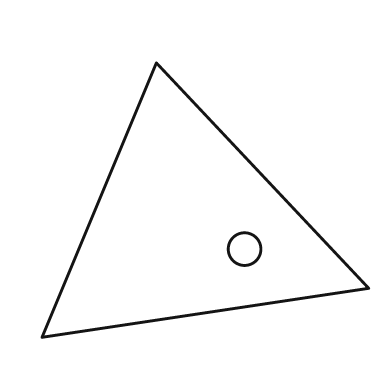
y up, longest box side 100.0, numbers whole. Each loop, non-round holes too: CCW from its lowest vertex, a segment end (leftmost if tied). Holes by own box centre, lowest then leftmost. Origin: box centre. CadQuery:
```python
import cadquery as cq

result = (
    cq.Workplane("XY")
    .moveTo(-50.0, -42.0)
    .lineTo(50.0, -27.0)
    .lineTo(-15.0, 42.0)
    .close()
    .moveTo(12.0, -15.0)
    .circle(5.0)
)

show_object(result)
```